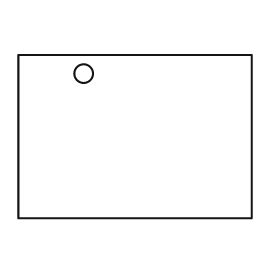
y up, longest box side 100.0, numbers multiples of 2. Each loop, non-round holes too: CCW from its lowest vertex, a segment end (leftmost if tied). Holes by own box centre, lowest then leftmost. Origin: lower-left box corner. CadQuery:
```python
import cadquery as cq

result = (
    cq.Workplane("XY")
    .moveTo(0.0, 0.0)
    .lineTo(100.0, 0.0)
    .lineTo(100.0, 70.0)
    .lineTo(0.0, 70.0)
    .close()
    .moveTo(28.0, 62.0)
    .circle(4.0)
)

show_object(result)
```